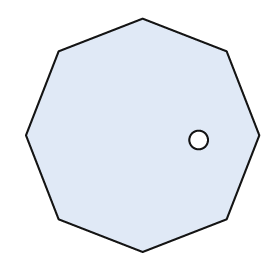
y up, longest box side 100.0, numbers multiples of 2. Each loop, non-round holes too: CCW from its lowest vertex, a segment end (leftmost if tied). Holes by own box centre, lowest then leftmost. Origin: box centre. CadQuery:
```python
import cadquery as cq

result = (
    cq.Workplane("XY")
    .moveTo(0.0, -50.0)
    .lineTo(36.0, -36.0)
    .lineTo(50.0, 0.0)
    .lineTo(36.0, 36.0)
    .lineTo(0.0, 50.0)
    .lineTo(-36.0, 36.0)
    .lineTo(-50.0, 0.0)
    .lineTo(-36.0, -36.0)
    .close()
    .moveTo(24.0, -2.0)
    .circle(4.0)
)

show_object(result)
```